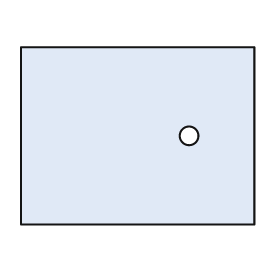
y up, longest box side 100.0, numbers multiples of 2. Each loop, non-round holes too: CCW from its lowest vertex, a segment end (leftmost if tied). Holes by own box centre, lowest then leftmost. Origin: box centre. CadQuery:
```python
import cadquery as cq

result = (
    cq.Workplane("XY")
    .moveTo(-50.0, -38.0)
    .lineTo(50.0, -38.0)
    .lineTo(50.0, 38.0)
    .lineTo(-50.0, 38.0)
    .close()
    .moveTo(22.0, 0.0)
    .circle(4.0)
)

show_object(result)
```